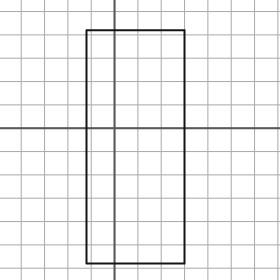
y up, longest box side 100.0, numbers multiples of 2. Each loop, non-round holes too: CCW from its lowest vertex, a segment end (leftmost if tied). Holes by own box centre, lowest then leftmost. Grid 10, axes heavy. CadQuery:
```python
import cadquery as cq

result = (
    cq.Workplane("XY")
    .moveTo(-12.0, -58.0)
    .lineTo(30.0, -58.0)
    .lineTo(30.0, 42.0)
    .lineTo(-12.0, 42.0)
    .close()
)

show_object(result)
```